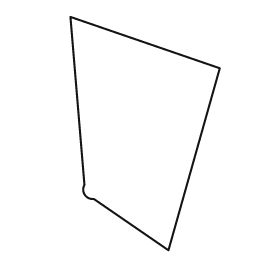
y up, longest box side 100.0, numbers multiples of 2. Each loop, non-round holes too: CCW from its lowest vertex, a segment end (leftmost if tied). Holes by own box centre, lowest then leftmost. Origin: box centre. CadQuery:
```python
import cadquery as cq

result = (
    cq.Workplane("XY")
    .moveTo(10.0, -50.0)
    .lineTo(32.0, 28.0)
    .lineTo(-32.0, 50.0)
    .lineTo(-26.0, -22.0)
    .threePointArc((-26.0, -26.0), (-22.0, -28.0))
    .close()
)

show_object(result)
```